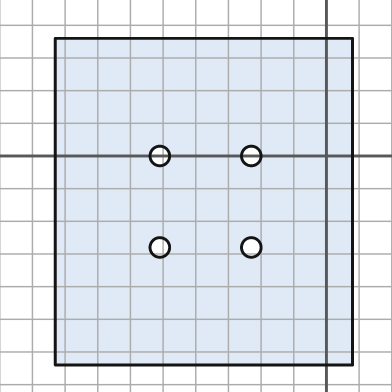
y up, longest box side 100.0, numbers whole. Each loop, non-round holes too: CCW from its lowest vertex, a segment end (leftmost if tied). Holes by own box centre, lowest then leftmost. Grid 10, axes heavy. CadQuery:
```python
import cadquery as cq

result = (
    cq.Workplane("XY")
    .moveTo(-83.0, -64.0)
    .lineTo(8.0, -64.0)
    .lineTo(8.0, 36.0)
    .lineTo(-83.0, 36.0)
    .close()
    .moveTo(-51.0, -28.0)
    .circle(3.0)
    .moveTo(-23.0, -28.0)
    .circle(3.0)
    .moveTo(-51.0, 0.0)
    .circle(3.0)
    .moveTo(-23.0, 0.0)
    .circle(3.0)
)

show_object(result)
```